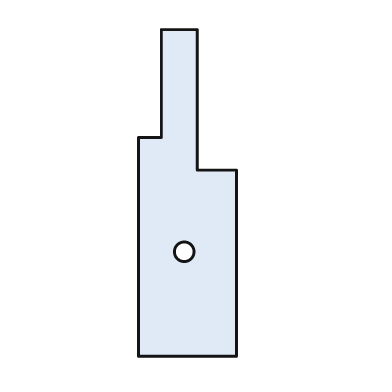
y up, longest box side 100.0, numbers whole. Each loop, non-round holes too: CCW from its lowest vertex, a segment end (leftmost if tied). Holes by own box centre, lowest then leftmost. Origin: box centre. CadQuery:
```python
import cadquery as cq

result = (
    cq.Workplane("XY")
    .moveTo(-15.0, -50.0)
    .lineTo(15.0, -50.0)
    .lineTo(15.0, 7.0)
    .lineTo(3.0, 7.0)
    .lineTo(3.0, 50.0)
    .lineTo(-8.0, 50.0)
    .lineTo(-8.0, 17.0)
    .lineTo(-15.0, 17.0)
    .close()
    .moveTo(-1.0, -18.0)
    .circle(3.0)
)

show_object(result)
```